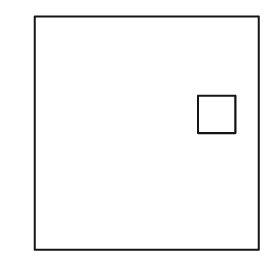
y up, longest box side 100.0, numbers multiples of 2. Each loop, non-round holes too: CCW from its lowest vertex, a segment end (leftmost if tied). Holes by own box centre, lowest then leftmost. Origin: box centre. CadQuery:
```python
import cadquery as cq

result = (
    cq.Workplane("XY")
    .moveTo(-48.0, -50.0)
    .lineTo(48.0, -50.0)
    .lineTo(48.0, 50.0)
    .lineTo(-48.0, 50.0)
    .close()
    .moveTo(22.0, 0.0)
    .lineTo(38.0, 0.0)
    .lineTo(38.0, 16.0)
    .lineTo(22.0, 16.0)
    .close()
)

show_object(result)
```